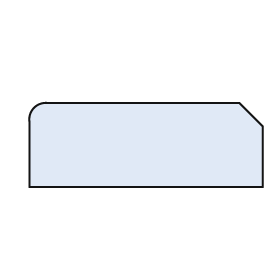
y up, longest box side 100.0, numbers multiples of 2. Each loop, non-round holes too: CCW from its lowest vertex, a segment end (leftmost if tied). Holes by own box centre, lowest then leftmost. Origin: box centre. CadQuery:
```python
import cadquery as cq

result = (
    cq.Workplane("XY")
    .moveTo(-50.0, -18.0)
    .lineTo(50.0, -18.0)
    .lineTo(50.0, 8.0)
    .lineTo(40.0, 18.0)
    .lineTo(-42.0, 18.0)
    .threePointArc((-48.0, 16.0), (-50.0, 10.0))
    .close()
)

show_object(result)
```